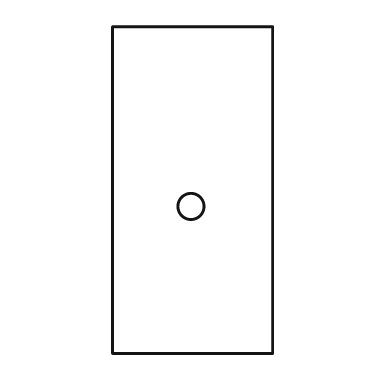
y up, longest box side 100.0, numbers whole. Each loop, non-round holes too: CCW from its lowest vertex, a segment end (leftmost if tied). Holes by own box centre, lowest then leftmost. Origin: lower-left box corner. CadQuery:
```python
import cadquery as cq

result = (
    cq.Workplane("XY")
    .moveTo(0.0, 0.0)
    .lineTo(49.0, 0.0)
    .lineTo(49.0, 100.0)
    .lineTo(0.0, 100.0)
    .close()
    .moveTo(24.0, 45.0)
    .circle(4.0)
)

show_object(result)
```